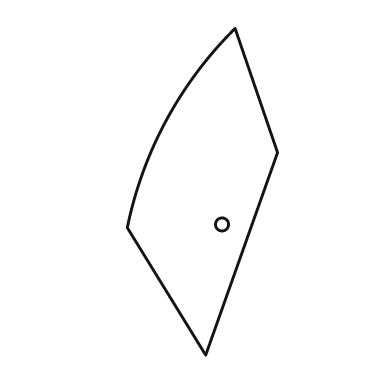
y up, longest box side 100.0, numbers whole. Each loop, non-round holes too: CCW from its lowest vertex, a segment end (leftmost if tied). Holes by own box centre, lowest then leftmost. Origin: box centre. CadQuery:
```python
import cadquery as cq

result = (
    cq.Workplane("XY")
    .moveTo(1.0, -50.0)
    .lineTo(23.0, 12.0)
    .lineTo(10.0, 50.0)
    .threePointArc((-11.0, 22.0), (-23.0, -11.0))
    .close()
    .moveTo(6.0, -10.0)
    .circle(2.0)
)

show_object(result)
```